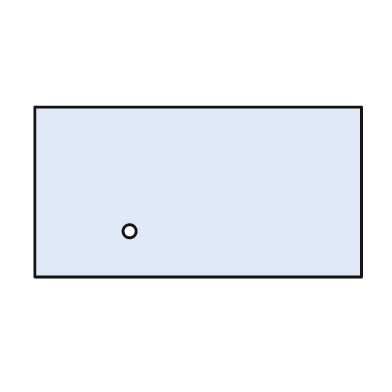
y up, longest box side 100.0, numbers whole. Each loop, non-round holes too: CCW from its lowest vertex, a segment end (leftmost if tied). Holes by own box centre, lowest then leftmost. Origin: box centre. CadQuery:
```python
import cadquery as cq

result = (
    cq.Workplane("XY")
    .moveTo(-50.0, -26.0)
    .lineTo(50.0, -26.0)
    .lineTo(50.0, 26.0)
    .lineTo(-50.0, 26.0)
    .close()
    .moveTo(-21.0, -12.0)
    .circle(2.0)
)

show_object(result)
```